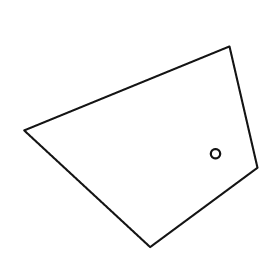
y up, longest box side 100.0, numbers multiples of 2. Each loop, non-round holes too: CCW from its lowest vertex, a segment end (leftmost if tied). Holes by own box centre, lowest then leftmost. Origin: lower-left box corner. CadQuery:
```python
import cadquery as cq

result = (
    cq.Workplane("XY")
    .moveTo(54.0, 0.0)
    .lineTo(100.0, 34.0)
    .lineTo(88.0, 86.0)
    .lineTo(0.0, 50.0)
    .close()
    .moveTo(82.0, 40.0)
    .circle(2.0)
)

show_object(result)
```